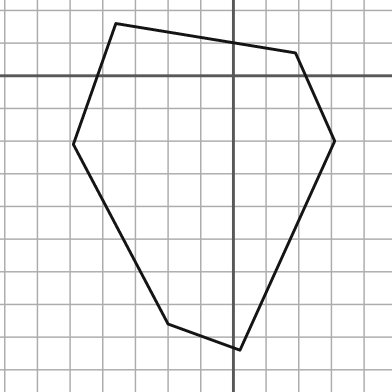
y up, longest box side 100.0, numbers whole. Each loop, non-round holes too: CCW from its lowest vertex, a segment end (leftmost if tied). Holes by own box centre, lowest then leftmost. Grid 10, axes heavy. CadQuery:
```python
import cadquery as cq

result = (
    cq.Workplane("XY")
    .moveTo(2.0, -84.0)
    .lineTo(31.0, -20.0)
    .lineTo(19.0, 7.0)
    .lineTo(-36.0, 16.0)
    .lineTo(-49.0, -21.0)
    .lineTo(-20.0, -76.0)
    .close()
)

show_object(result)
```